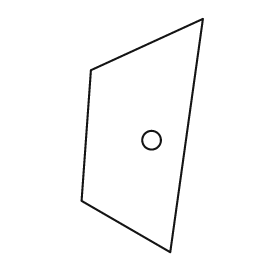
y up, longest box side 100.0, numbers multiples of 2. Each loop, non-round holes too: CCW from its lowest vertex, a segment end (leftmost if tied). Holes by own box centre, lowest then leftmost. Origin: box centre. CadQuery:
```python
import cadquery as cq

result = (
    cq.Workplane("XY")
    .moveTo(12.0, -50.0)
    .lineTo(26.0, 50.0)
    .lineTo(-22.0, 28.0)
    .lineTo(-26.0, -28.0)
    .close()
    .moveTo(4.0, -2.0)
    .circle(4.0)
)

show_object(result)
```